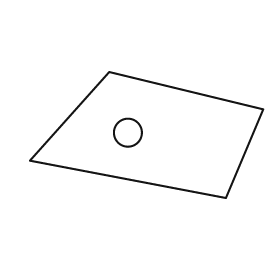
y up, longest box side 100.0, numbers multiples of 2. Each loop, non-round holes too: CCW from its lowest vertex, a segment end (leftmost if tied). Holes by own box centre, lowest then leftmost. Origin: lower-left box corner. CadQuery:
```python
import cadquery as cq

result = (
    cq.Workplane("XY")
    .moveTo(84.0, 0.0)
    .lineTo(100.0, 38.0)
    .lineTo(34.0, 54.0)
    .lineTo(0.0, 16.0)
    .close()
    .moveTo(42.0, 28.0)
    .circle(6.0)
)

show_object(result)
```